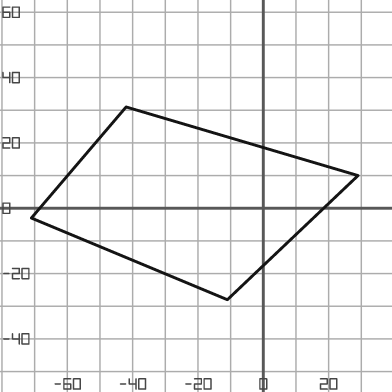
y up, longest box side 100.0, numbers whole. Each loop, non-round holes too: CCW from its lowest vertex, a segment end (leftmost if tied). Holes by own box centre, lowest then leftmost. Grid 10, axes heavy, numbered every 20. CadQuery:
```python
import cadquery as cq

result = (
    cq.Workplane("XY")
    .moveTo(-11.0, -28.0)
    .lineTo(29.0, 10.0)
    .lineTo(-42.0, 31.0)
    .lineTo(-71.0, -3.0)
    .close()
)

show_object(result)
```